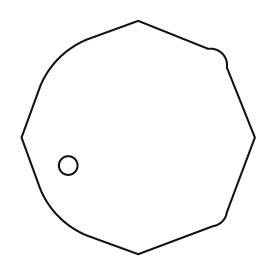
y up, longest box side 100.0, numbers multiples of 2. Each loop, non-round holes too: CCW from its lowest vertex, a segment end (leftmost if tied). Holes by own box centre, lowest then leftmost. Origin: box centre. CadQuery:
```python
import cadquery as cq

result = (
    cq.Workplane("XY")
    .moveTo(0.0, -50.0)
    .lineTo(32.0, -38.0)
    .threePointArc((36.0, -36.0), (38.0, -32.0))
    .lineTo(50.0, 0.0)
    .lineTo(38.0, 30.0)
    .threePointArc((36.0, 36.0), (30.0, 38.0))
    .lineTo(0.0, 50.0)
    .lineTo(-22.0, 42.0)
    .threePointArc((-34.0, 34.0), (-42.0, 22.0))
    .lineTo(-50.0, 0.0)
    .lineTo(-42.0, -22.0)
    .threePointArc((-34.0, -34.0), (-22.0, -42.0))
    .close()
    .moveTo(-30.0, -12.0)
    .circle(4.0)
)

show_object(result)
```